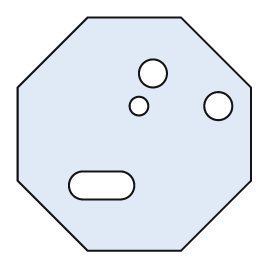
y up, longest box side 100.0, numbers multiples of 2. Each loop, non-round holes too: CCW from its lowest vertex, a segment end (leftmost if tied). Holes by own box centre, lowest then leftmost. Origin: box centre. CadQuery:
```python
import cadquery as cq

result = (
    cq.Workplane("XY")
    .moveTo(-20.0, -50.0)
    .lineTo(20.0, -50.0)
    .lineTo(50.0, -20.0)
    .lineTo(50.0, 20.0)
    .lineTo(20.0, 50.0)
    .lineTo(-20.0, 50.0)
    .lineTo(-50.0, 20.0)
    .lineTo(-50.0, -20.0)
    .close()
    .moveTo(-22.0, -28.0)
    .lineTo(-6.0, -28.0)
    .threePointArc((0.0, -22.0), (-6.0, -16.0))
    .lineTo(-22.0, -16.0)
    .threePointArc((-28.0, -22.0), (-22.0, -28.0))
    .close()
    .moveTo(2.0, 12.0)
    .circle(4.0)
    .moveTo(36.0, 12.0)
    .circle(6.0)
    .moveTo(8.0, 26.0)
    .circle(6.0)
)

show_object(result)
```